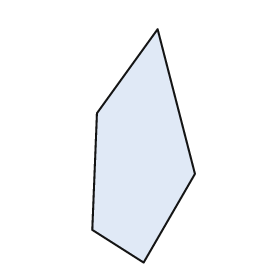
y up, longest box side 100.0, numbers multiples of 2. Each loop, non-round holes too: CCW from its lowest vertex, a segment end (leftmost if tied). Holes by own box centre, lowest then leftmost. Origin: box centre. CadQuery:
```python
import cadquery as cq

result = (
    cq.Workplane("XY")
    .moveTo(0.0, -50.0)
    .lineTo(22.0, -12.0)
    .lineTo(6.0, 50.0)
    .lineTo(-20.0, 14.0)
    .lineTo(-22.0, -36.0)
    .close()
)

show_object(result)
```